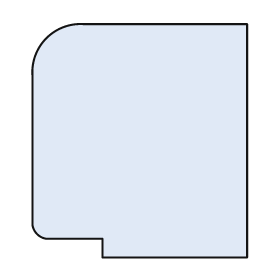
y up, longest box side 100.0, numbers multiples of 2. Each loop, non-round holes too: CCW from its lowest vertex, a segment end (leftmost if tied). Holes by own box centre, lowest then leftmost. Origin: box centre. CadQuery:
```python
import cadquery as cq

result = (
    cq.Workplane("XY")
    .moveTo(-16.0, -50.0)
    .lineTo(46.0, -50.0)
    .lineTo(46.0, 50.0)
    .lineTo(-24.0, 50.0)
    .threePointArc((-40.0, 44.0), (-46.0, 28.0))
    .lineTo(-46.0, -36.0)
    .threePointArc((-44.0, -40.0), (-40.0, -42.0))
    .lineTo(-16.0, -42.0)
    .close()
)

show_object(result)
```